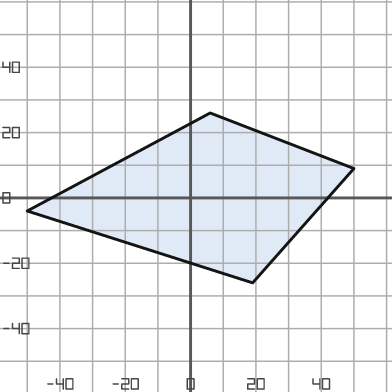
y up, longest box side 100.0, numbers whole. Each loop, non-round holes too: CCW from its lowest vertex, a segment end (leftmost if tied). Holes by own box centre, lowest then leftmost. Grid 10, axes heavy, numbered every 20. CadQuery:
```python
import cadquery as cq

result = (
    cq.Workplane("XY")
    .moveTo(19.0, -26.0)
    .lineTo(50.0, 9.0)
    .lineTo(6.0, 26.0)
    .lineTo(-50.0, -4.0)
    .close()
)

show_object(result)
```